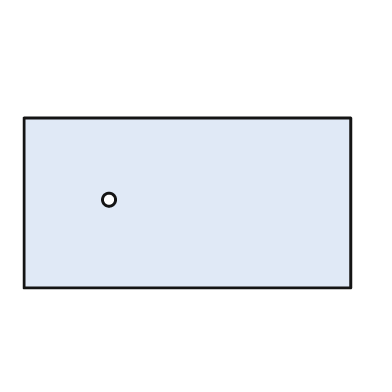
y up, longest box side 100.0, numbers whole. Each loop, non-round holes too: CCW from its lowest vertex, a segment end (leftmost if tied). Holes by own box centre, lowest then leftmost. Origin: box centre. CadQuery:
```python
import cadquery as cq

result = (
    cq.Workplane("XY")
    .moveTo(-50.0, -26.0)
    .lineTo(50.0, -26.0)
    .lineTo(50.0, 26.0)
    .lineTo(-50.0, 26.0)
    .close()
    .moveTo(-24.0, 1.0)
    .circle(2.0)
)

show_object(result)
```